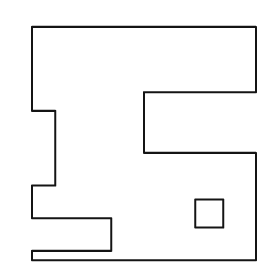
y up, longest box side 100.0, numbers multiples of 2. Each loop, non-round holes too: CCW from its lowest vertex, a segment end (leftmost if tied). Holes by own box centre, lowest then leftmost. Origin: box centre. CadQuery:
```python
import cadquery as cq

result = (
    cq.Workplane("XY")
    .moveTo(-48.0, -50.0)
    .lineTo(48.0, -50.0)
    .lineTo(48.0, -4.0)
    .lineTo(0.0, -4.0)
    .lineTo(0.0, 22.0)
    .lineTo(48.0, 22.0)
    .lineTo(48.0, 50.0)
    .lineTo(-48.0, 50.0)
    .lineTo(-48.0, 14.0)
    .lineTo(-38.0, 14.0)
    .lineTo(-38.0, -18.0)
    .lineTo(-48.0, -18.0)
    .lineTo(-48.0, -32.0)
    .lineTo(-14.0, -32.0)
    .lineTo(-14.0, -46.0)
    .lineTo(-48.0, -46.0)
    .close()
    .moveTo(22.0, -36.0)
    .lineTo(34.0, -36.0)
    .lineTo(34.0, -24.0)
    .lineTo(22.0, -24.0)
    .close()
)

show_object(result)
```